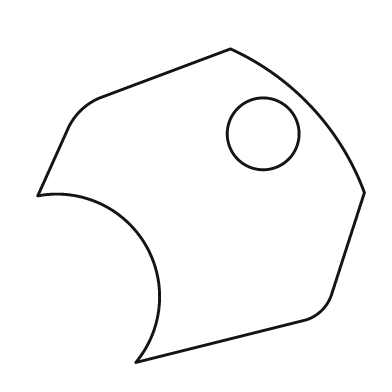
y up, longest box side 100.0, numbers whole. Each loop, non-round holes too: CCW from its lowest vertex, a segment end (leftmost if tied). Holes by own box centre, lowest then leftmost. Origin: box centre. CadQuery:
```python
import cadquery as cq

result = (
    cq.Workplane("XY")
    .moveTo(-20.0, -48.0)
    .lineTo(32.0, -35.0)
    .threePointArc((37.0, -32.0), (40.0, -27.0))
    .lineTo(50.0, 4.0)
    .threePointArc((34.0, 30.0), (9.0, 48.0))
    .lineTo(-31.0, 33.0)
    .threePointArc((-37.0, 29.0), (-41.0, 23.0))
    .lineTo(-50.0, 3.0)
    .threePointArc((-17.0, -12.0), (-20.0, -48.0))
    .close()
    .moveTo(19.0, 22.0)
    .circle(11.0)
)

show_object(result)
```